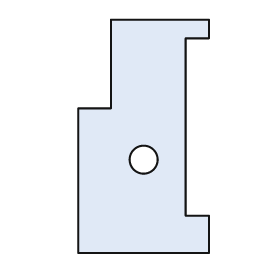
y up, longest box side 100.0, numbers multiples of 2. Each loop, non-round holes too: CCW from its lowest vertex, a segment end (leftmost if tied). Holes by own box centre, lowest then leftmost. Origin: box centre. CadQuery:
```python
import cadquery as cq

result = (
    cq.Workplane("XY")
    .moveTo(-28.0, -50.0)
    .lineTo(28.0, -50.0)
    .lineTo(28.0, -34.0)
    .lineTo(18.0, -34.0)
    .lineTo(18.0, 42.0)
    .lineTo(28.0, 42.0)
    .lineTo(28.0, 50.0)
    .lineTo(-14.0, 50.0)
    .lineTo(-14.0, 12.0)
    .lineTo(-28.0, 12.0)
    .close()
    .moveTo(0.0, -10.0)
    .circle(6.0)
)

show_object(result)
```